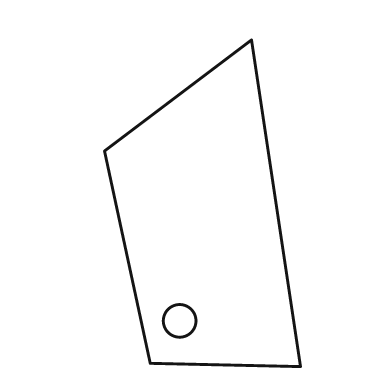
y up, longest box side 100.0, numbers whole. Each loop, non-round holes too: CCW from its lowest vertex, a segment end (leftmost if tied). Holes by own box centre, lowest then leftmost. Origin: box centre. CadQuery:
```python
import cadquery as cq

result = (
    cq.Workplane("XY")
    .moveTo(30.0, -50.0)
    .lineTo(15.0, 50.0)
    .lineTo(-30.0, 16.0)
    .lineTo(-16.0, -49.0)
    .close()
    .moveTo(-7.0, -36.0)
    .circle(5.0)
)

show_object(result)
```